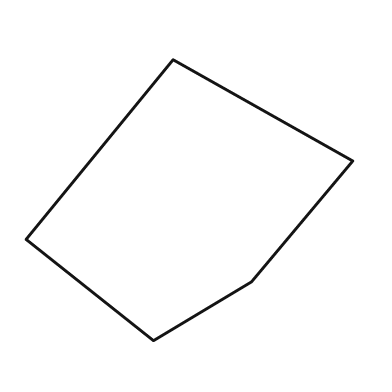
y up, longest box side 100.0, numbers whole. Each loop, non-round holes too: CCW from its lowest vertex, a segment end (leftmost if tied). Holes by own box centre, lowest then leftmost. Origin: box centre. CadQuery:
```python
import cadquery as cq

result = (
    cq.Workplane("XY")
    .moveTo(-11.0, -43.0)
    .lineTo(19.0, -25.0)
    .lineTo(50.0, 12.0)
    .lineTo(-5.0, 43.0)
    .lineTo(-50.0, -12.0)
    .close()
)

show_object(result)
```